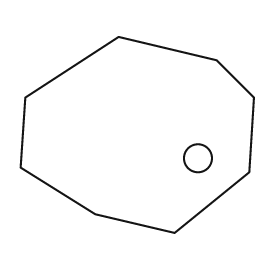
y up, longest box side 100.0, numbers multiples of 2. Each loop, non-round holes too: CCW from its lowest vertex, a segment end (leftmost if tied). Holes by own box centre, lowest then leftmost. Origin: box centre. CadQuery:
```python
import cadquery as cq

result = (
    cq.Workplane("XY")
    .moveTo(16.0, -42.0)
    .lineTo(48.0, -16.0)
    .lineTo(50.0, 16.0)
    .lineTo(34.0, 32.0)
    .lineTo(-8.0, 42.0)
    .lineTo(-48.0, 16.0)
    .lineTo(-50.0, -14.0)
    .lineTo(-18.0, -34.0)
    .close()
    .moveTo(26.0, -10.0)
    .circle(6.0)
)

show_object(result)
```